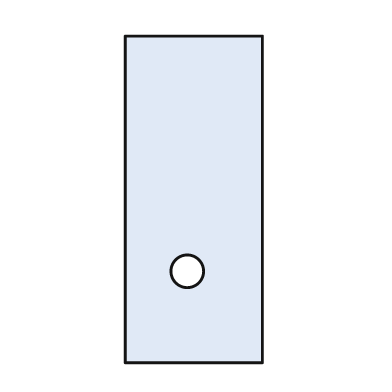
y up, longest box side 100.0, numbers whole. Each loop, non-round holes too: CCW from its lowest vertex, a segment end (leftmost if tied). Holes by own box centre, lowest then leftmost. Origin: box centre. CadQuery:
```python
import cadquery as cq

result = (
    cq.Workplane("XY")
    .moveTo(-21.0, -50.0)
    .lineTo(21.0, -50.0)
    .lineTo(21.0, 50.0)
    .lineTo(-21.0, 50.0)
    .close()
    .moveTo(-2.0, -22.0)
    .circle(5.0)
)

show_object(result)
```